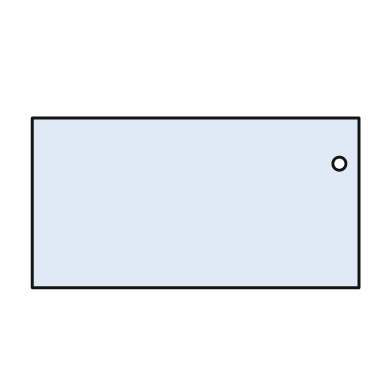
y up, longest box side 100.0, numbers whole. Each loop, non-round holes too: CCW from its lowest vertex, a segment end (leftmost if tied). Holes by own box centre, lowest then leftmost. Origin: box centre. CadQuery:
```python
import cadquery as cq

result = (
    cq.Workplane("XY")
    .moveTo(-50.0, -26.0)
    .lineTo(50.0, -26.0)
    .lineTo(50.0, 26.0)
    .lineTo(-50.0, 26.0)
    .close()
    .moveTo(44.0, 12.0)
    .circle(2.0)
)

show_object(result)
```